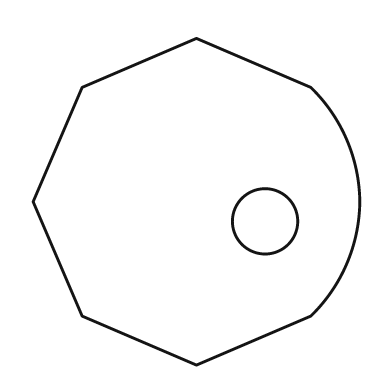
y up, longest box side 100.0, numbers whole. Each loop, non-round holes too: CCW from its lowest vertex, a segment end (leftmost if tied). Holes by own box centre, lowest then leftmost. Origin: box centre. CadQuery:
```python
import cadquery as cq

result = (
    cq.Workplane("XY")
    .moveTo(0.0, -50.0)
    .lineTo(35.0, -35.0)
    .threePointArc((46.0, -19.0), (50.0, 0.0))
    .threePointArc((46.0, 19.0), (35.0, 35.0))
    .lineTo(0.0, 50.0)
    .lineTo(-35.0, 35.0)
    .lineTo(-50.0, 0.0)
    .lineTo(-35.0, -35.0)
    .close()
    .moveTo(21.0, -6.0)
    .circle(10.0)
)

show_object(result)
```